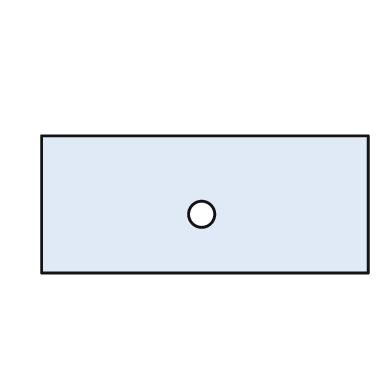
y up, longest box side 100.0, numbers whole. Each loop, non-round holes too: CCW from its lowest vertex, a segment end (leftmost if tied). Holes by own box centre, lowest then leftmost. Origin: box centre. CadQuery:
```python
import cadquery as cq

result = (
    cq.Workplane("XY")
    .moveTo(-50.0, -21.0)
    .lineTo(50.0, -21.0)
    .lineTo(50.0, 21.0)
    .lineTo(-50.0, 21.0)
    .close()
    .moveTo(-1.0, -3.0)
    .circle(4.0)
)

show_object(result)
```